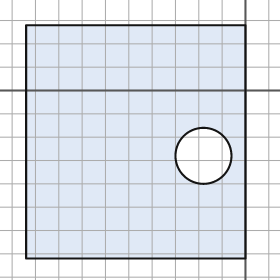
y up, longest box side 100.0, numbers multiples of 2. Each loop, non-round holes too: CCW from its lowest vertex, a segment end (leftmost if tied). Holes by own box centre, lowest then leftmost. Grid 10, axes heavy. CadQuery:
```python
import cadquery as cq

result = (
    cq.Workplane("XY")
    .moveTo(-94.0, -72.0)
    .lineTo(0.0, -72.0)
    .lineTo(0.0, 28.0)
    .lineTo(-94.0, 28.0)
    .close()
    .moveTo(-18.0, -28.0)
    .circle(12.0)
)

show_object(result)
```